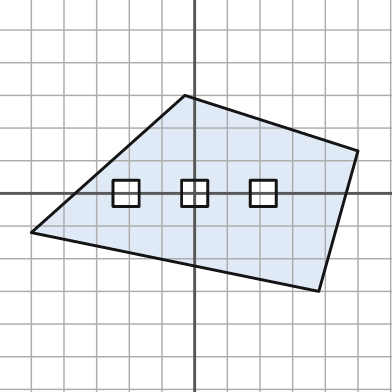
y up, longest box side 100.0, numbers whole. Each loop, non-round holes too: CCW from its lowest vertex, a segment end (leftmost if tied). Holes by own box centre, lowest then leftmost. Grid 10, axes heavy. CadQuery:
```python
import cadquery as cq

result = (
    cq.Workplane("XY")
    .moveTo(38.0, -30.0)
    .lineTo(50.0, 13.0)
    .lineTo(-3.0, 30.0)
    .lineTo(-50.0, -12.0)
    .close()
    .moveTo(-25.0, -4.0)
    .lineTo(-17.0, -4.0)
    .lineTo(-17.0, 4.0)
    .lineTo(-25.0, 4.0)
    .close()
    .moveTo(-4.0, -4.0)
    .lineTo(4.0, -4.0)
    .lineTo(4.0, 4.0)
    .lineTo(-4.0, 4.0)
    .close()
    .moveTo(17.0, -4.0)
    .lineTo(25.0, -4.0)
    .lineTo(25.0, 4.0)
    .lineTo(17.0, 4.0)
    .close()
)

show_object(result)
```